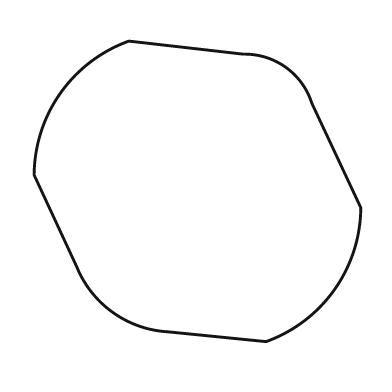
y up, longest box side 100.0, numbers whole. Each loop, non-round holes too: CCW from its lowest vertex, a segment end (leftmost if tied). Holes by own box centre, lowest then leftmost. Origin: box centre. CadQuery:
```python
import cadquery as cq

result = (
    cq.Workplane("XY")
    .moveTo(21.0, -46.0)
    .threePointArc((42.0, -30.0), (50.0, -5.0))
    .lineTo(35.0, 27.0)
    .threePointArc((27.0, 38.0), (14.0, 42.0))
    .lineTo(-21.0, 46.0)
    .threePointArc((-42.0, 30.0), (-50.0, 5.0))
    .lineTo(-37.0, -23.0)
    .threePointArc((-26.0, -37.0), (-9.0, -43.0))
    .close()
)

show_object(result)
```